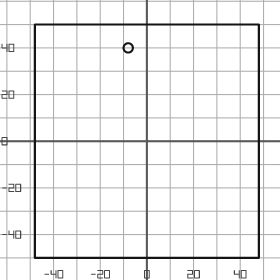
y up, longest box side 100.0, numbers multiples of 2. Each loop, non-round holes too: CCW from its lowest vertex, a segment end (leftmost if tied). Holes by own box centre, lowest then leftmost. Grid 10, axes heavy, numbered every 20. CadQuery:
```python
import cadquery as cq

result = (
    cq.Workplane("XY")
    .moveTo(-48.0, -50.0)
    .lineTo(48.0, -50.0)
    .lineTo(48.0, 50.0)
    .lineTo(-48.0, 50.0)
    .close()
    .moveTo(-8.0, 40.0)
    .circle(2.0)
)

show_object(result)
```